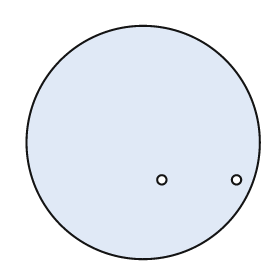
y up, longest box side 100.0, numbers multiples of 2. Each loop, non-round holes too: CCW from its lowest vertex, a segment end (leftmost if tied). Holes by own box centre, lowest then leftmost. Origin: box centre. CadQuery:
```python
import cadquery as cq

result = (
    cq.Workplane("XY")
    .moveTo(0.0, 0.0)
    .circle(50.0)
    .moveTo(8.0, -16.0)
    .circle(2.0)
    .moveTo(40.0, -16.0)
    .circle(2.0)
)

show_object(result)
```